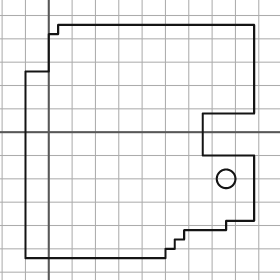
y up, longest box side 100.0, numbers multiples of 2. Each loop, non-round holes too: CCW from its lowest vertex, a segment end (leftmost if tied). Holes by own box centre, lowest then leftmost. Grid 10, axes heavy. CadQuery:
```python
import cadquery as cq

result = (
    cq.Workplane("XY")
    .moveTo(-10.0, -54.0)
    .lineTo(50.0, -54.0)
    .lineTo(50.0, -50.0)
    .lineTo(54.0, -50.0)
    .lineTo(54.0, -46.0)
    .lineTo(58.0, -46.0)
    .lineTo(58.0, -42.0)
    .lineTo(76.0, -42.0)
    .lineTo(76.0, -38.0)
    .lineTo(88.0, -38.0)
    .lineTo(88.0, -10.0)
    .lineTo(66.0, -10.0)
    .lineTo(66.0, 8.0)
    .lineTo(88.0, 8.0)
    .lineTo(88.0, 46.0)
    .lineTo(4.0, 46.0)
    .lineTo(4.0, 42.0)
    .lineTo(0.0, 42.0)
    .lineTo(0.0, 26.0)
    .lineTo(-10.0, 26.0)
    .close()
    .moveTo(76.0, -20.0)
    .circle(4.0)
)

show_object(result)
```